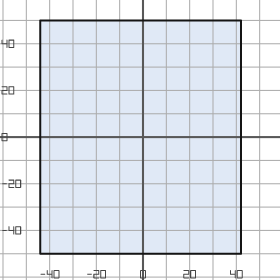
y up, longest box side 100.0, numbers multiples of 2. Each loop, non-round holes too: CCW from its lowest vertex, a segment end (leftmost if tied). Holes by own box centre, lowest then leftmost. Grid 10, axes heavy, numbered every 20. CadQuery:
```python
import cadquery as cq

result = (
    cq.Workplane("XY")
    .moveTo(-44.0, -50.0)
    .lineTo(42.0, -50.0)
    .lineTo(42.0, 50.0)
    .lineTo(-44.0, 50.0)
    .close()
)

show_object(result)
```